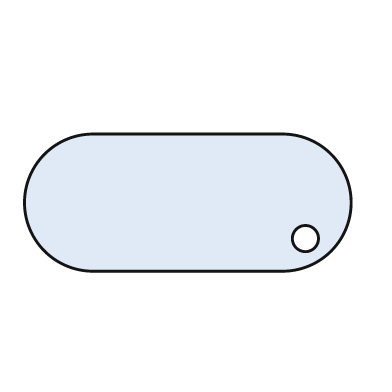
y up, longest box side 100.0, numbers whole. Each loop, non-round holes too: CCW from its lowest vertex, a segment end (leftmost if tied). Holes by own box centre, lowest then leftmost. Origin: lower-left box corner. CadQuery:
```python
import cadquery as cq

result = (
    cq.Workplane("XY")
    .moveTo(21.0, 0.0)
    .lineTo(79.0, 0.0)
    .threePointArc((100.0, 21.0), (79.0, 42.0))
    .lineTo(21.0, 42.0)
    .threePointArc((0.0, 21.0), (21.0, 0.0))
    .close()
    .moveTo(86.0, 10.0)
    .circle(4.0)
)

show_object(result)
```